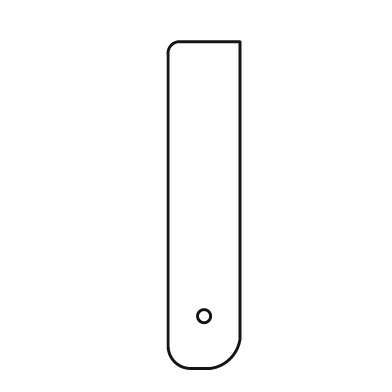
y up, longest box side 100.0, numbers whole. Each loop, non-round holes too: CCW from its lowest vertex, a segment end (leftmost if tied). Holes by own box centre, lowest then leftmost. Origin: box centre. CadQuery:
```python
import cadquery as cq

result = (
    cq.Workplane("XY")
    .moveTo(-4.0, -50.0)
    .lineTo(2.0, -50.0)
    .threePointArc((8.0, -47.0), (11.0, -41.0))
    .lineTo(11.0, 50.0)
    .lineTo(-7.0, 50.0)
    .threePointArc((-10.0, 49.0), (-11.0, 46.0))
    .lineTo(-11.0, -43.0)
    .threePointArc((-9.0, -48.0), (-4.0, -50.0))
    .close()
    .moveTo(0.0, -34.0)
    .circle(2.0)
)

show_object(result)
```